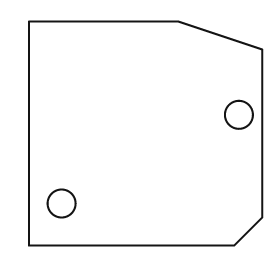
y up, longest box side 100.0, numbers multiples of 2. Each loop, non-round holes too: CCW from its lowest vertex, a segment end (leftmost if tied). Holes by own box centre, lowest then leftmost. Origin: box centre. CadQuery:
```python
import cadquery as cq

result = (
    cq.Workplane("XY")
    .moveTo(-50.0, -48.0)
    .lineTo(38.0, -48.0)
    .lineTo(50.0, -36.0)
    .lineTo(50.0, 36.0)
    .lineTo(14.0, 48.0)
    .lineTo(-50.0, 48.0)
    .close()
    .moveTo(-36.0, -30.0)
    .circle(6.0)
    .moveTo(40.0, 8.0)
    .circle(6.0)
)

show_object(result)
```